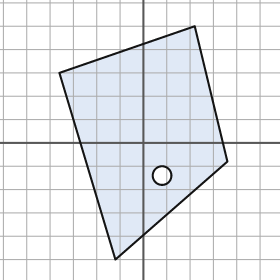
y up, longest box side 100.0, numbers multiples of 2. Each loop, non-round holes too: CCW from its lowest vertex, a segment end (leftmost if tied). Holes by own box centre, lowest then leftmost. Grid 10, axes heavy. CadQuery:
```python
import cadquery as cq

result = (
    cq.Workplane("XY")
    .moveTo(-12.0, -50.0)
    .lineTo(36.0, -8.0)
    .lineTo(22.0, 50.0)
    .lineTo(-36.0, 30.0)
    .close()
    .moveTo(8.0, -14.0)
    .circle(4.0)
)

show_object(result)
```